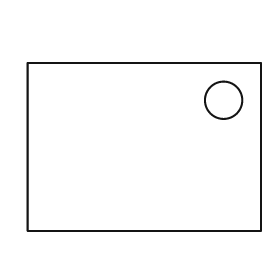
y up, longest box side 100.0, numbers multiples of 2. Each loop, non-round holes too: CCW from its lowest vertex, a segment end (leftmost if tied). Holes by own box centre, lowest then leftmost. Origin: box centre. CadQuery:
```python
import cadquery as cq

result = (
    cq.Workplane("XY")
    .moveTo(-50.0, -36.0)
    .lineTo(50.0, -36.0)
    .lineTo(50.0, 36.0)
    .lineTo(-50.0, 36.0)
    .close()
    .moveTo(34.0, 20.0)
    .circle(8.0)
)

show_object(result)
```